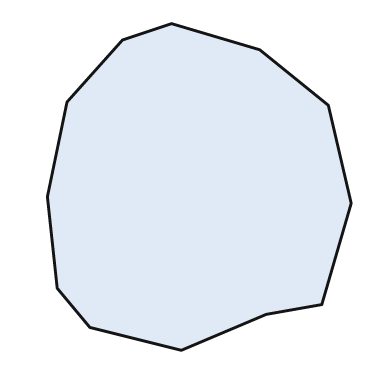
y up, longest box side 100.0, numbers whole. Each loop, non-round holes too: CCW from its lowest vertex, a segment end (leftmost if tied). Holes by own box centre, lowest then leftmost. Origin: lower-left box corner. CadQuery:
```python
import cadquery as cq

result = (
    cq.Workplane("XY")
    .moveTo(41.0, 0.0)
    .lineTo(67.0, 11.0)
    .lineTo(84.0, 14.0)
    .lineTo(93.0, 45.0)
    .lineTo(86.0, 75.0)
    .lineTo(65.0, 92.0)
    .lineTo(38.0, 100.0)
    .lineTo(23.0, 95.0)
    .lineTo(6.0, 76.0)
    .lineTo(0.0, 47.0)
    .lineTo(3.0, 19.0)
    .lineTo(13.0, 7.0)
    .close()
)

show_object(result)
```